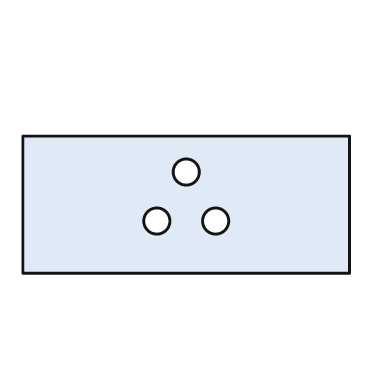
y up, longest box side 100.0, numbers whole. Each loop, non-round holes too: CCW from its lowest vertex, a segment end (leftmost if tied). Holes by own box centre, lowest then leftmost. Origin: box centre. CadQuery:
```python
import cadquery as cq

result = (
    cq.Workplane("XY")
    .moveTo(-50.0, -21.0)
    .lineTo(50.0, -21.0)
    .lineTo(50.0, 21.0)
    .lineTo(-50.0, 21.0)
    .close()
    .moveTo(-9.0, -5.0)
    .circle(4.0)
    .moveTo(9.0, -5.0)
    .circle(4.0)
    .moveTo(0.0, 10.0)
    .circle(4.0)
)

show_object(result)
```